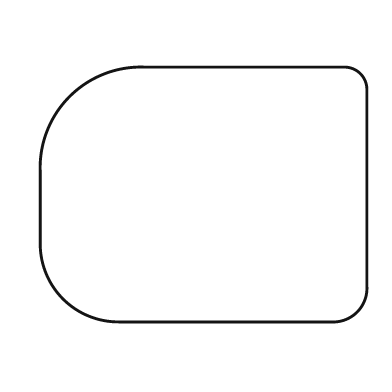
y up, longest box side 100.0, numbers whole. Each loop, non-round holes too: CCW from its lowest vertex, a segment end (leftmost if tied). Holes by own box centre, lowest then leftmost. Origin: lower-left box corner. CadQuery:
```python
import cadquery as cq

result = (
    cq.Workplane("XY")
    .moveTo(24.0, 0.0)
    .lineTo(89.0, 0.0)
    .threePointArc((97.0, 3.0), (100.0, 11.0))
    .lineTo(100.0, 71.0)
    .threePointArc((98.0, 76.0), (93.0, 78.0))
    .lineTo(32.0, 78.0)
    .threePointArc((9.0, 69.0), (0.0, 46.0))
    .lineTo(0.0, 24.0)
    .threePointArc((7.0, 7.0), (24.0, 0.0))
    .close()
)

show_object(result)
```